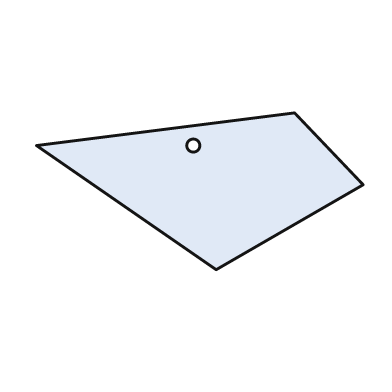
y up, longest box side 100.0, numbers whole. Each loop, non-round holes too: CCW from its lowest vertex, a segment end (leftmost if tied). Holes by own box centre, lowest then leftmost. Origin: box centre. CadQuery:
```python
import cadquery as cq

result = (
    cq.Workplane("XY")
    .moveTo(5.0, -24.0)
    .lineTo(50.0, 2.0)
    .lineTo(29.0, 24.0)
    .lineTo(-50.0, 14.0)
    .close()
    .moveTo(-2.0, 14.0)
    .circle(2.0)
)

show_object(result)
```